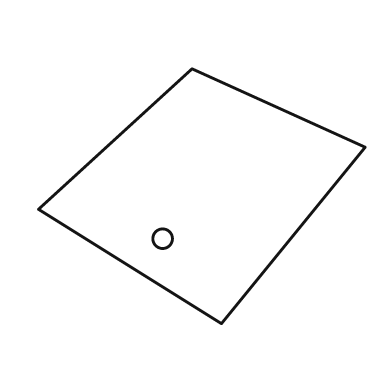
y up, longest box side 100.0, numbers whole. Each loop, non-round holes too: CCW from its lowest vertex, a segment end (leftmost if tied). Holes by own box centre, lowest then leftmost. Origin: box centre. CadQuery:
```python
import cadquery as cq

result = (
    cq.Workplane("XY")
    .moveTo(6.0, -39.0)
    .lineTo(50.0, 15.0)
    .lineTo(-3.0, 39.0)
    .lineTo(-50.0, -4.0)
    .close()
    .moveTo(-12.0, -13.0)
    .circle(3.0)
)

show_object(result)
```